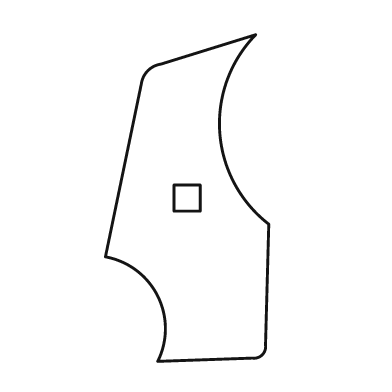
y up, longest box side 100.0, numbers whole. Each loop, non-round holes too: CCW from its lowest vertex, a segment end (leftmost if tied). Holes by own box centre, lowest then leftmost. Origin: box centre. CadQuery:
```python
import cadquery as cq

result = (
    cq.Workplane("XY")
    .moveTo(-9.0, -50.0)
    .lineTo(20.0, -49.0)
    .threePointArc((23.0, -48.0), (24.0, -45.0))
    .lineTo(25.0, -8.0)
    .threePointArc((10.0, 20.0), (21.0, 50.0))
    .lineTo(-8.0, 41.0)
    .threePointArc((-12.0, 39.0), (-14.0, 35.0))
    .lineTo(-25.0, -18.0)
    .threePointArc((-9.0, -30.0), (-9.0, -50.0))
    .close()
    .moveTo(-4.0, -4.0)
    .lineTo(4.0, -4.0)
    .lineTo(4.0, 4.0)
    .lineTo(-4.0, 4.0)
    .close()
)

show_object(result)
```